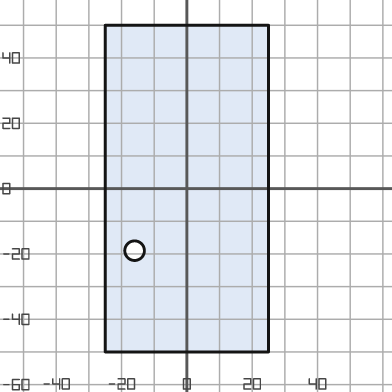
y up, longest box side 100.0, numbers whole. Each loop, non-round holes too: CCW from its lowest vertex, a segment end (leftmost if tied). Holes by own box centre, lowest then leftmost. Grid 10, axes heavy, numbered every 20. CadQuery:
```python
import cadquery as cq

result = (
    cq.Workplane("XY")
    .moveTo(-25.0, -50.0)
    .lineTo(25.0, -50.0)
    .lineTo(25.0, 50.0)
    .lineTo(-25.0, 50.0)
    .close()
    .moveTo(-16.0, -19.0)
    .circle(3.0)
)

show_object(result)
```